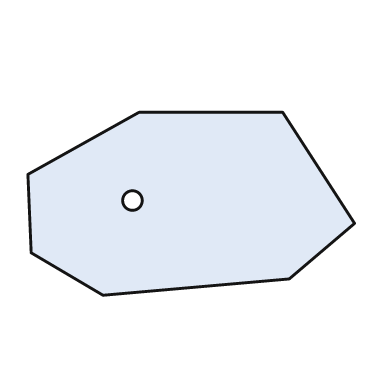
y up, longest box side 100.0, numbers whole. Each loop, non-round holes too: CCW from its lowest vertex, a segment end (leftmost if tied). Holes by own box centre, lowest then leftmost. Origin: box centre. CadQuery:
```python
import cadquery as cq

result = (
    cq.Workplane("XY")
    .moveTo(-27.0, -28.0)
    .lineTo(30.0, -23.0)
    .lineTo(50.0, -6.0)
    .lineTo(28.0, 28.0)
    .lineTo(-16.0, 28.0)
    .lineTo(-50.0, 9.0)
    .lineTo(-49.0, -15.0)
    .close()
    .moveTo(-18.0, 1.0)
    .circle(3.0)
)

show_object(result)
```